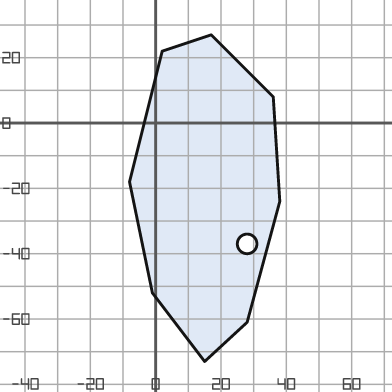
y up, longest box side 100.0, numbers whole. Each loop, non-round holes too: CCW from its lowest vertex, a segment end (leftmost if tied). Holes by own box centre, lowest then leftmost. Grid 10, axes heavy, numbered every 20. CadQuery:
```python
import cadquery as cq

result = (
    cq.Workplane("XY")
    .moveTo(15.0, -73.0)
    .lineTo(28.0, -61.0)
    .lineTo(38.0, -24.0)
    .lineTo(36.0, 8.0)
    .lineTo(17.0, 27.0)
    .lineTo(2.0, 22.0)
    .lineTo(-8.0, -18.0)
    .lineTo(-1.0, -52.0)
    .close()
    .moveTo(28.0, -37.0)
    .circle(3.0)
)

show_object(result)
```